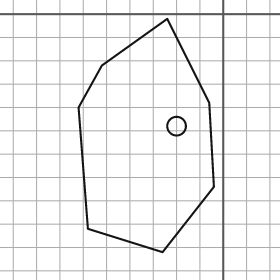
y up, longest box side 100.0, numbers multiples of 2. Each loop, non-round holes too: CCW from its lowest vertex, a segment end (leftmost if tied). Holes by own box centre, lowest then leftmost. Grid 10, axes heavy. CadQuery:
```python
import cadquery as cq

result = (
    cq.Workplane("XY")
    .moveTo(-26.0, -102.0)
    .lineTo(-4.0, -74.0)
    .lineTo(-6.0, -38.0)
    .lineTo(-24.0, -2.0)
    .lineTo(-52.0, -22.0)
    .lineTo(-62.0, -40.0)
    .lineTo(-58.0, -92.0)
    .close()
    .moveTo(-20.0, -48.0)
    .circle(4.0)
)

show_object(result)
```